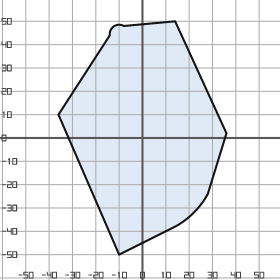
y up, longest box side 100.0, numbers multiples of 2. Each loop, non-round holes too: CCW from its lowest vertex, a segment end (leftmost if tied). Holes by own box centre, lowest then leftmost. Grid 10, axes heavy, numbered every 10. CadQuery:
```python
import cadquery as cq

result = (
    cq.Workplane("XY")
    .moveTo(-10.0, -50.0)
    .lineTo(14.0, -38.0)
    .threePointArc((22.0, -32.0), (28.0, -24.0))
    .lineTo(36.0, 2.0)
    .lineTo(14.0, 50.0)
    .lineTo(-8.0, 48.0)
    .threePointArc((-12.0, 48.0), (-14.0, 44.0))
    .lineTo(-36.0, 10.0)
    .close()
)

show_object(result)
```